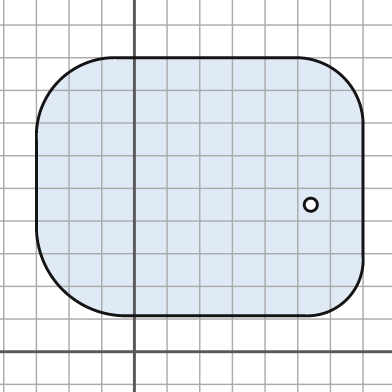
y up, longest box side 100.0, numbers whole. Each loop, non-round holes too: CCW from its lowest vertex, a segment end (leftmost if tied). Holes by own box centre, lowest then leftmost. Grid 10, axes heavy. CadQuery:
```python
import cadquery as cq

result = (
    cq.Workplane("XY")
    .moveTo(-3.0, 11.0)
    .lineTo(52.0, 11.0)
    .threePointArc((65.0, 16.0), (70.0, 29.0))
    .lineTo(70.0, 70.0)
    .threePointArc((64.0, 84.0), (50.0, 90.0))
    .lineTo(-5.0, 90.0)
    .threePointArc((-23.0, 83.0), (-30.0, 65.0))
    .lineTo(-30.0, 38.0)
    .threePointArc((-22.0, 19.0), (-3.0, 11.0))
    .close()
    .moveTo(54.0, 45.0)
    .circle(2.0)
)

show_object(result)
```